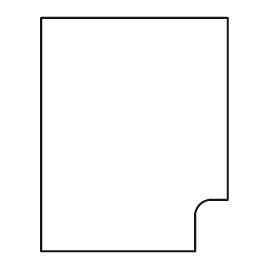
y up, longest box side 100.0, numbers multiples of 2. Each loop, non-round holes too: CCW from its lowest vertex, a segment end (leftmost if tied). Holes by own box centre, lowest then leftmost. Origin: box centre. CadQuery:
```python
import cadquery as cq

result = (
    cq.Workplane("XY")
    .moveTo(-40.0, -50.0)
    .lineTo(26.0, -50.0)
    .lineTo(26.0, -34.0)
    .threePointArc((28.0, -30.0), (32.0, -28.0))
    .lineTo(40.0, -28.0)
    .lineTo(40.0, 50.0)
    .lineTo(-40.0, 50.0)
    .close()
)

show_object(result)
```